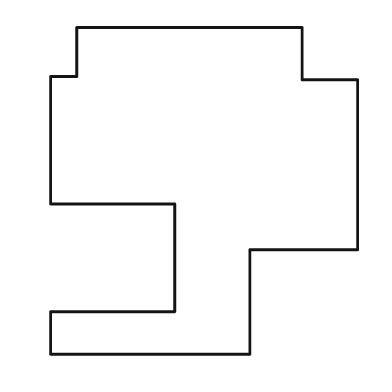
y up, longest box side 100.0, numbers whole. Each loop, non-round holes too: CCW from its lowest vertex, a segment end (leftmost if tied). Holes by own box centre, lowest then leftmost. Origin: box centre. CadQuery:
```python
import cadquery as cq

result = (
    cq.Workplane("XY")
    .moveTo(-47.0, -50.0)
    .lineTo(14.0, -50.0)
    .lineTo(14.0, -18.0)
    .lineTo(47.0, -18.0)
    .lineTo(47.0, 34.0)
    .lineTo(30.0, 34.0)
    .lineTo(30.0, 50.0)
    .lineTo(-39.0, 50.0)
    .lineTo(-39.0, 35.0)
    .lineTo(-47.0, 35.0)
    .lineTo(-47.0, -4.0)
    .lineTo(-9.0, -4.0)
    .lineTo(-9.0, -37.0)
    .lineTo(-47.0, -37.0)
    .close()
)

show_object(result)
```